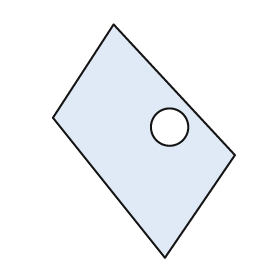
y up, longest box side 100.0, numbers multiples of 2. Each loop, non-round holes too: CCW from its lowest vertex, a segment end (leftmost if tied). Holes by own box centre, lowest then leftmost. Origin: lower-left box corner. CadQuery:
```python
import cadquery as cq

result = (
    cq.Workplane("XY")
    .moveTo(48.0, 0.0)
    .lineTo(78.0, 44.0)
    .lineTo(26.0, 100.0)
    .lineTo(0.0, 60.0)
    .close()
    .moveTo(50.0, 56.0)
    .circle(8.0)
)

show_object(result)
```